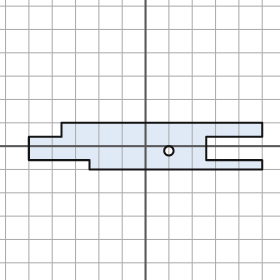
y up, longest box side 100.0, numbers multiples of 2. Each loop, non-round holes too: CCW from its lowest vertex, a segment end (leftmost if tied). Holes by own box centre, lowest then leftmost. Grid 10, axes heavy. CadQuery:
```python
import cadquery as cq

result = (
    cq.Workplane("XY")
    .moveTo(-24.0, -10.0)
    .lineTo(50.0, -10.0)
    .lineTo(50.0, -6.0)
    .lineTo(26.0, -6.0)
    .lineTo(26.0, 4.0)
    .lineTo(50.0, 4.0)
    .lineTo(50.0, 10.0)
    .lineTo(-36.0, 10.0)
    .lineTo(-36.0, 4.0)
    .lineTo(-50.0, 4.0)
    .lineTo(-50.0, -6.0)
    .lineTo(-24.0, -6.0)
    .close()
    .moveTo(10.0, -2.0)
    .circle(2.0)
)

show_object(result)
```